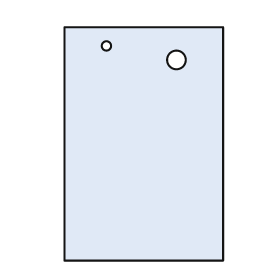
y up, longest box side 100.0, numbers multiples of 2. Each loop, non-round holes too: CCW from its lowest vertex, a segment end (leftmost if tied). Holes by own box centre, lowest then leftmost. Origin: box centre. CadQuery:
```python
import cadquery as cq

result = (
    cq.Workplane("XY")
    .moveTo(-34.0, -50.0)
    .lineTo(34.0, -50.0)
    .lineTo(34.0, 50.0)
    .lineTo(-34.0, 50.0)
    .close()
    .moveTo(14.0, 36.0)
    .circle(4.0)
    .moveTo(-16.0, 42.0)
    .circle(2.0)
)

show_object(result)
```